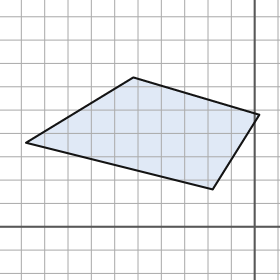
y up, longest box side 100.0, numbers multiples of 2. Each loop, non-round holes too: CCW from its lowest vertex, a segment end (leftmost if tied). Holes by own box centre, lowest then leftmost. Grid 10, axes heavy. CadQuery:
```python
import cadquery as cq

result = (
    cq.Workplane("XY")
    .moveTo(-18.0, 16.0)
    .lineTo(2.0, 48.0)
    .lineTo(-52.0, 64.0)
    .lineTo(-98.0, 36.0)
    .close()
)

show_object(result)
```